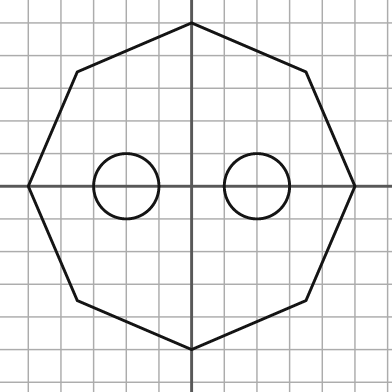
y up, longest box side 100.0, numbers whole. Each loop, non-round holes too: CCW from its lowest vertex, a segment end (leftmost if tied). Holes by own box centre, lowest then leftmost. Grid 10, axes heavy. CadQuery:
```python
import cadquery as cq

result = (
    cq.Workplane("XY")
    .moveTo(0.0, -50.0)
    .lineTo(35.0, -35.0)
    .lineTo(50.0, 0.0)
    .lineTo(35.0, 35.0)
    .lineTo(0.0, 50.0)
    .lineTo(-35.0, 35.0)
    .lineTo(-50.0, 0.0)
    .lineTo(-35.0, -35.0)
    .close()
    .moveTo(-20.0, 0.0)
    .circle(10.0)
    .moveTo(20.0, 0.0)
    .circle(10.0)
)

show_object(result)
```